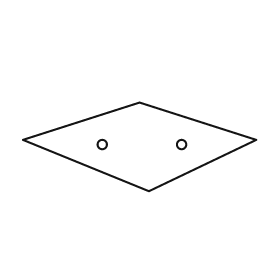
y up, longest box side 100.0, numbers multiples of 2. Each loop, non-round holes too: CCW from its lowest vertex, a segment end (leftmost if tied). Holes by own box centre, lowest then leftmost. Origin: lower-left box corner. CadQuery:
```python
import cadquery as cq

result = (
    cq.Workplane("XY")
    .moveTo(54.0, 0.0)
    .lineTo(100.0, 22.0)
    .lineTo(50.0, 38.0)
    .lineTo(0.0, 22.0)
    .close()
    .moveTo(34.0, 20.0)
    .circle(2.0)
    .moveTo(68.0, 20.0)
    .circle(2.0)
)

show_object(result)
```